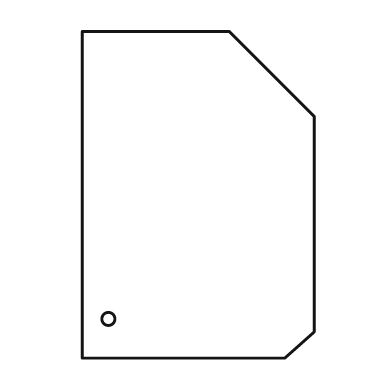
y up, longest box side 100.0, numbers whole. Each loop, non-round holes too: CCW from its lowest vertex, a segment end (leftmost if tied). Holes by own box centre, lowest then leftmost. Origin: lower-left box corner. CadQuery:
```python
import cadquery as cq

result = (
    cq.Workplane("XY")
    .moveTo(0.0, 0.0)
    .lineTo(62.0, 0.0)
    .lineTo(71.0, 8.0)
    .lineTo(71.0, 74.0)
    .lineTo(45.0, 100.0)
    .lineTo(0.0, 100.0)
    .close()
    .moveTo(8.0, 12.0)
    .circle(2.0)
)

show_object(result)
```